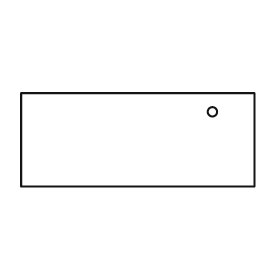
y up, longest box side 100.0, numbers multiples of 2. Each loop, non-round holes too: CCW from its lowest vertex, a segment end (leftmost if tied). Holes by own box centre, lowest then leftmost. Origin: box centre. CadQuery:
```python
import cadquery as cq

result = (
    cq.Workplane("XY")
    .moveTo(-50.0, -20.0)
    .lineTo(50.0, -20.0)
    .lineTo(50.0, 20.0)
    .lineTo(-50.0, 20.0)
    .close()
    .moveTo(32.0, 12.0)
    .circle(2.0)
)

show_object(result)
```